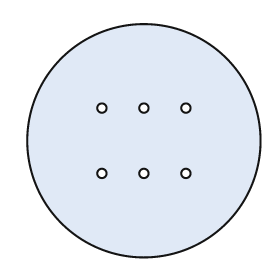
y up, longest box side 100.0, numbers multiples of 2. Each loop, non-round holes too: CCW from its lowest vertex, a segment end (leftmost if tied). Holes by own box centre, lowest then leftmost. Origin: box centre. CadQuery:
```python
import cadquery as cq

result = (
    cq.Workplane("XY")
    .moveTo(0.0, 0.0)
    .circle(50.0)
    .moveTo(-18.0, -14.0)
    .circle(2.0)
    .moveTo(0.0, -14.0)
    .circle(2.0)
    .moveTo(18.0, -14.0)
    .circle(2.0)
    .moveTo(-18.0, 14.0)
    .circle(2.0)
    .moveTo(0.0, 14.0)
    .circle(2.0)
    .moveTo(18.0, 14.0)
    .circle(2.0)
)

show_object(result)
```